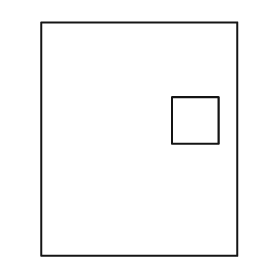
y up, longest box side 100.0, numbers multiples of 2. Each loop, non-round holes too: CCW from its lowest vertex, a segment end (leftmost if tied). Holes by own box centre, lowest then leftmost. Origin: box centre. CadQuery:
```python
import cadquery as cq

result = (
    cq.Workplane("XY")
    .moveTo(-42.0, -50.0)
    .lineTo(42.0, -50.0)
    .lineTo(42.0, 50.0)
    .lineTo(-42.0, 50.0)
    .close()
    .moveTo(14.0, -2.0)
    .lineTo(34.0, -2.0)
    .lineTo(34.0, 18.0)
    .lineTo(14.0, 18.0)
    .close()
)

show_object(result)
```